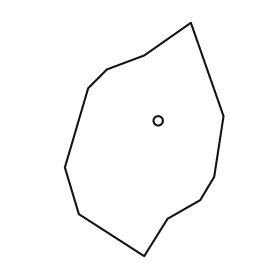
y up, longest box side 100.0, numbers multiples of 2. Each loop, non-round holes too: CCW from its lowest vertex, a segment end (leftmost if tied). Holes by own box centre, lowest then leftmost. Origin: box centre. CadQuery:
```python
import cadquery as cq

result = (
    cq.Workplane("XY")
    .moveTo(0.0, -50.0)
    .lineTo(10.0, -34.0)
    .lineTo(24.0, -26.0)
    .lineTo(30.0, -16.0)
    .lineTo(34.0, 10.0)
    .lineTo(20.0, 50.0)
    .lineTo(0.0, 36.0)
    .lineTo(-16.0, 30.0)
    .lineTo(-24.0, 22.0)
    .lineTo(-34.0, -12.0)
    .lineTo(-28.0, -32.0)
    .close()
    .moveTo(6.0, 8.0)
    .circle(2.0)
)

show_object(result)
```